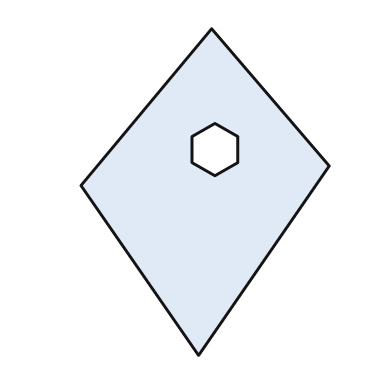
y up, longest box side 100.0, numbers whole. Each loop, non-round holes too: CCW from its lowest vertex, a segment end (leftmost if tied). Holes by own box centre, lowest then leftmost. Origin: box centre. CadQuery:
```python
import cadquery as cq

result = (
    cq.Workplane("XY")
    .moveTo(-2.0, -50.0)
    .lineTo(38.0, 8.0)
    .lineTo(2.0, 50.0)
    .lineTo(-38.0, 2.0)
    .close()
    .moveTo(3.0, 5.0)
    .lineTo(10.0, 9.0)
    .lineTo(10.0, 17.0)
    .lineTo(3.0, 21.0)
    .lineTo(-4.0, 17.0)
    .lineTo(-4.0, 9.0)
    .close()
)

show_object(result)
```